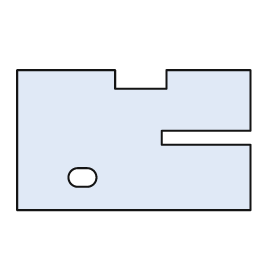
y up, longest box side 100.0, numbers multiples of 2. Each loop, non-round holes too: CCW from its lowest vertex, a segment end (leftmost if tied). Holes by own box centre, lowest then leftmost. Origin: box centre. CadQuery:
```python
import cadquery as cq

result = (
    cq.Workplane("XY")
    .moveTo(-50.0, -30.0)
    .lineTo(50.0, -30.0)
    .lineTo(50.0, -2.0)
    .lineTo(12.0, -2.0)
    .lineTo(12.0, 4.0)
    .lineTo(50.0, 4.0)
    .lineTo(50.0, 30.0)
    .lineTo(14.0, 30.0)
    .lineTo(14.0, 22.0)
    .lineTo(-8.0, 22.0)
    .lineTo(-8.0, 30.0)
    .lineTo(-50.0, 30.0)
    .close()
    .moveTo(-24.0, -20.0)
    .lineTo(-20.0, -20.0)
    .threePointArc((-16.0, -16.0), (-20.0, -12.0))
    .lineTo(-24.0, -12.0)
    .threePointArc((-28.0, -16.0), (-24.0, -20.0))
    .close()
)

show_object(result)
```